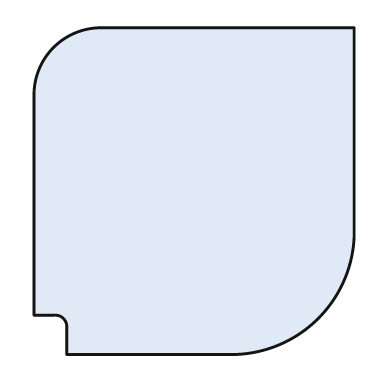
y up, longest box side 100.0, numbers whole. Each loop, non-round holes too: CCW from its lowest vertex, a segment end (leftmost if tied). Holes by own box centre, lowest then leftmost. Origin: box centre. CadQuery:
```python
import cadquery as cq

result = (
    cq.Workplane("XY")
    .moveTo(-39.0, -50.0)
    .lineTo(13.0, -50.0)
    .threePointArc((38.0, -39.0), (49.0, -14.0))
    .lineTo(49.0, 50.0)
    .lineTo(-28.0, 50.0)
    .threePointArc((-43.0, 44.0), (-49.0, 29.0))
    .lineTo(-49.0, -38.0)
    .lineTo(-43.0, -38.0)
    .threePointArc((-40.0, -39.0), (-39.0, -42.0))
    .close()
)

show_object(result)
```